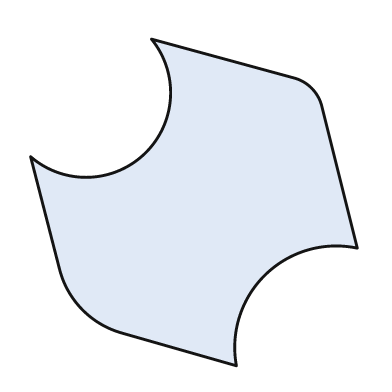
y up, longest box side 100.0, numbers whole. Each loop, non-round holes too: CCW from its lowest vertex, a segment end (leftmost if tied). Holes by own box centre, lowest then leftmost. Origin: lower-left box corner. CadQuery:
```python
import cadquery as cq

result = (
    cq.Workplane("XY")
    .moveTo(63.0, 0.0)
    .threePointArc((72.0, 28.0), (100.0, 36.0))
    .lineTo(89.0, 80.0)
    .threePointArc((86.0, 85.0), (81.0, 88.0))
    .lineTo(37.0, 100.0)
    .threePointArc((35.0, 65.0), (0.0, 64.0))
    .lineTo(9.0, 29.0)
    .threePointArc((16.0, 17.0), (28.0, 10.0))
    .close()
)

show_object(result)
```